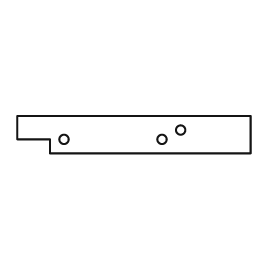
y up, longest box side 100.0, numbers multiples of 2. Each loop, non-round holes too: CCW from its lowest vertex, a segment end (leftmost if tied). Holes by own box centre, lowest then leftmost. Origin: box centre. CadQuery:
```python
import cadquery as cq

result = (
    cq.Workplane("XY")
    .moveTo(-36.0, -8.0)
    .lineTo(50.0, -8.0)
    .lineTo(50.0, 8.0)
    .lineTo(-50.0, 8.0)
    .lineTo(-50.0, -2.0)
    .lineTo(-36.0, -2.0)
    .close()
    .moveTo(-30.0, -2.0)
    .circle(2.0)
    .moveTo(12.0, -2.0)
    .circle(2.0)
    .moveTo(20.0, 2.0)
    .circle(2.0)
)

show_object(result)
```